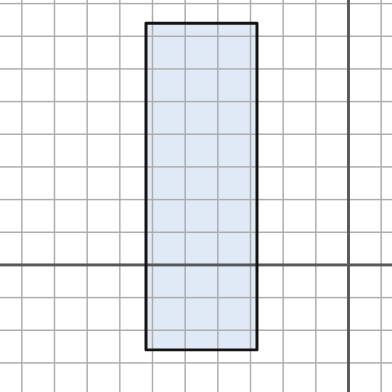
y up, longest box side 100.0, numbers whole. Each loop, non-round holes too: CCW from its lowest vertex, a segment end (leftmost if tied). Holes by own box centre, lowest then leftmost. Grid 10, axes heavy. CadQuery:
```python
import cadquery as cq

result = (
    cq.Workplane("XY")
    .moveTo(-62.0, -26.0)
    .lineTo(-28.0, -26.0)
    .lineTo(-28.0, 74.0)
    .lineTo(-62.0, 74.0)
    .close()
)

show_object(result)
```